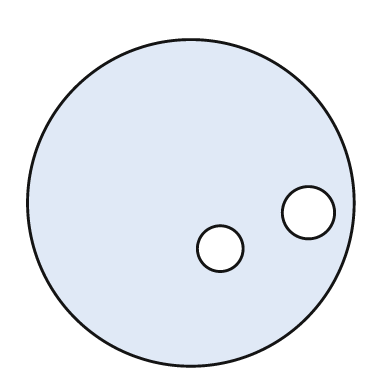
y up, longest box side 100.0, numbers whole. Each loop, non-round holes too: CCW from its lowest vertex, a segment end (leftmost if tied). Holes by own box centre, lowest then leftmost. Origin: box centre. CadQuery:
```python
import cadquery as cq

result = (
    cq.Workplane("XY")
    .moveTo(0.0, 0.0)
    .circle(50.0)
    .moveTo(9.0, -14.0)
    .circle(7.0)
    .moveTo(36.0, -3.0)
    .circle(8.0)
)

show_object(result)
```